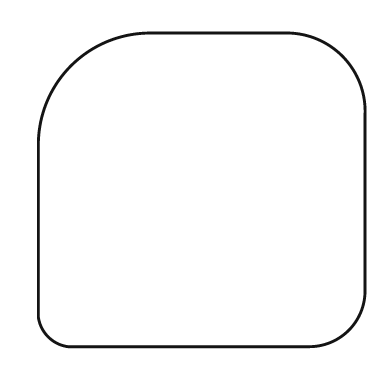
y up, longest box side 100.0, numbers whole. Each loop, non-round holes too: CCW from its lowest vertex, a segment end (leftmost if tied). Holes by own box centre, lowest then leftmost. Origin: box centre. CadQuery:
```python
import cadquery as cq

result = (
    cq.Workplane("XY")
    .moveTo(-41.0, -48.0)
    .lineTo(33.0, -48.0)
    .threePointArc((45.0, -43.0), (50.0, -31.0))
    .lineTo(50.0, 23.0)
    .threePointArc((43.0, 41.0), (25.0, 48.0))
    .lineTo(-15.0, 48.0)
    .threePointArc((-40.0, 38.0), (-50.0, 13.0))
    .lineTo(-50.0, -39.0)
    .threePointArc((-47.0, -45.0), (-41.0, -48.0))
    .close()
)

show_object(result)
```